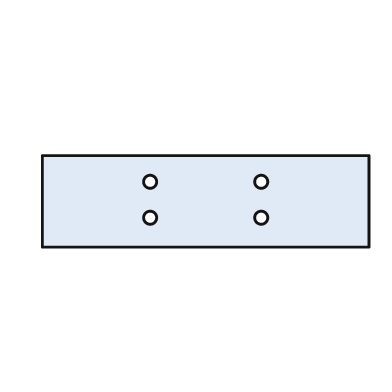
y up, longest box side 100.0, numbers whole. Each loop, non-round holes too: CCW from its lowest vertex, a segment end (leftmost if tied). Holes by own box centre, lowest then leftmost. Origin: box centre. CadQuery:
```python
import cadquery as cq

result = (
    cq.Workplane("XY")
    .moveTo(-50.0, -14.0)
    .lineTo(50.0, -14.0)
    .lineTo(50.0, 14.0)
    .lineTo(-50.0, 14.0)
    .close()
    .moveTo(-17.0, -5.0)
    .circle(2.0)
    .moveTo(17.0, -5.0)
    .circle(2.0)
    .moveTo(-17.0, 6.0)
    .circle(2.0)
    .moveTo(17.0, 6.0)
    .circle(2.0)
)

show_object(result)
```